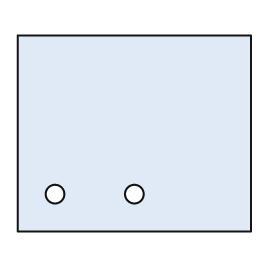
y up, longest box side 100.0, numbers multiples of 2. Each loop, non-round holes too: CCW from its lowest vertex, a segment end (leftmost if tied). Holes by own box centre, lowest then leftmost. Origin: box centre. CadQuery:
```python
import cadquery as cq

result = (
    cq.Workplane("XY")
    .moveTo(-50.0, -42.0)
    .lineTo(50.0, -42.0)
    .lineTo(50.0, 42.0)
    .lineTo(-50.0, 42.0)
    .close()
    .moveTo(-34.0, -26.0)
    .circle(4.0)
    .moveTo(0.0, -26.0)
    .circle(4.0)
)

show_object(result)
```